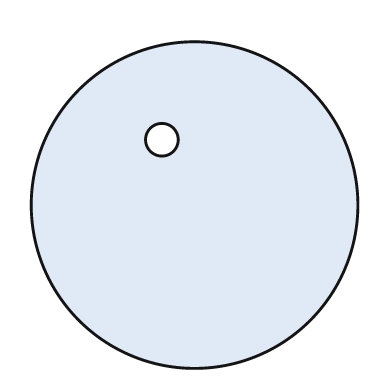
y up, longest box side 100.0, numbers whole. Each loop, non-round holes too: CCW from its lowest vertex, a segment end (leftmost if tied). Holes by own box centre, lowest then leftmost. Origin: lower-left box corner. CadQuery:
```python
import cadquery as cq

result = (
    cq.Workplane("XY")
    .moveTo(50.0, 50.0)
    .circle(50.0)
    .moveTo(40.0, 70.0)
    .circle(5.0)
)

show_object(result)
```